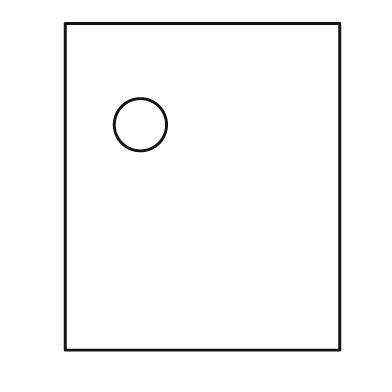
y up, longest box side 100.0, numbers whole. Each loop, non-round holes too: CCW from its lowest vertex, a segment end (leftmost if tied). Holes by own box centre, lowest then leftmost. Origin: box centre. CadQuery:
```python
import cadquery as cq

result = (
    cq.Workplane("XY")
    .moveTo(-42.0, -50.0)
    .lineTo(42.0, -50.0)
    .lineTo(42.0, 50.0)
    .lineTo(-42.0, 50.0)
    .close()
    .moveTo(-19.0, 19.0)
    .circle(8.0)
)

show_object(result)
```